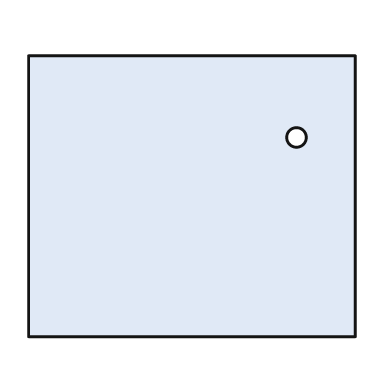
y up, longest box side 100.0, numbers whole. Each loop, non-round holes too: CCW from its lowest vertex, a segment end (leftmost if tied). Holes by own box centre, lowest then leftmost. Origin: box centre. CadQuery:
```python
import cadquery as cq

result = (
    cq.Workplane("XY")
    .moveTo(-50.0, -43.0)
    .lineTo(50.0, -43.0)
    .lineTo(50.0, 43.0)
    .lineTo(-50.0, 43.0)
    .close()
    .moveTo(32.0, 18.0)
    .circle(3.0)
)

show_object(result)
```